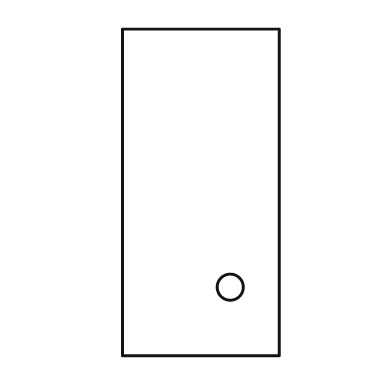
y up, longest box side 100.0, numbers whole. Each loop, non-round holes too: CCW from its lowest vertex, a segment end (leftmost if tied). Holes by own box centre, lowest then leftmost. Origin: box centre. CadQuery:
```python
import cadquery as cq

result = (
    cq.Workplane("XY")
    .moveTo(-24.0, -50.0)
    .lineTo(24.0, -50.0)
    .lineTo(24.0, 50.0)
    .lineTo(-24.0, 50.0)
    .close()
    .moveTo(9.0, -29.0)
    .circle(4.0)
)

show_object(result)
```